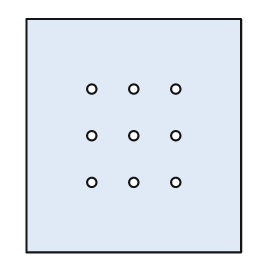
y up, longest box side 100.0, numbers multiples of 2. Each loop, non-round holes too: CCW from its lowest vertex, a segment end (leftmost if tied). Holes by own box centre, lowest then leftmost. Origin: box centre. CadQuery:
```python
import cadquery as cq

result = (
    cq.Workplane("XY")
    .moveTo(-46.0, -50.0)
    .lineTo(46.0, -50.0)
    .lineTo(46.0, 50.0)
    .lineTo(-46.0, 50.0)
    .close()
    .moveTo(-18.0, -20.0)
    .circle(2.0)
    .moveTo(0.0, -20.0)
    .circle(2.0)
    .moveTo(18.0, -20.0)
    .circle(2.0)
    .moveTo(-18.0, 0.0)
    .circle(2.0)
    .moveTo(0.0, 0.0)
    .circle(2.0)
    .moveTo(18.0, 0.0)
    .circle(2.0)
    .moveTo(-18.0, 20.0)
    .circle(2.0)
    .moveTo(0.0, 20.0)
    .circle(2.0)
    .moveTo(18.0, 20.0)
    .circle(2.0)
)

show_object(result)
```